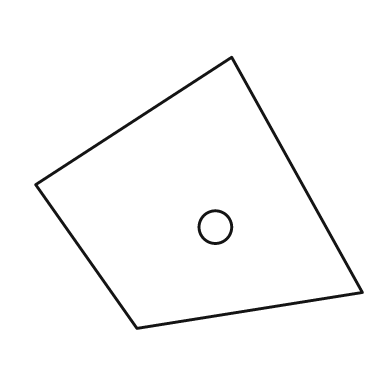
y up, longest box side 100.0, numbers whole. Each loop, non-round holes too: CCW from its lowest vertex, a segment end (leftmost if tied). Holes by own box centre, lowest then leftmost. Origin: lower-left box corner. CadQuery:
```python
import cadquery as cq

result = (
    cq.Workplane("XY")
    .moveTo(31.0, 0.0)
    .lineTo(100.0, 11.0)
    .lineTo(60.0, 83.0)
    .lineTo(0.0, 44.0)
    .close()
    .moveTo(55.0, 31.0)
    .circle(5.0)
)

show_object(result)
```